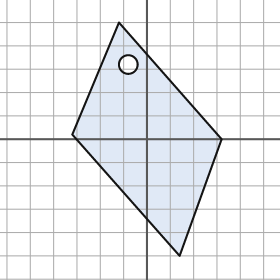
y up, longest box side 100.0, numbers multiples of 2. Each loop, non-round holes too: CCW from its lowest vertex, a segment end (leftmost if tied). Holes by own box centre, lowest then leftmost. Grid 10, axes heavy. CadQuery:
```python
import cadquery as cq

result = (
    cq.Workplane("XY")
    .moveTo(14.0, -50.0)
    .lineTo(32.0, 0.0)
    .lineTo(-12.0, 50.0)
    .lineTo(-32.0, 2.0)
    .close()
    .moveTo(-8.0, 32.0)
    .circle(4.0)
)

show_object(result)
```